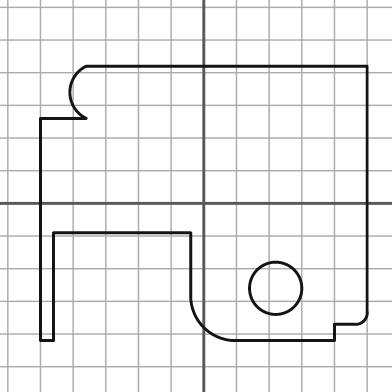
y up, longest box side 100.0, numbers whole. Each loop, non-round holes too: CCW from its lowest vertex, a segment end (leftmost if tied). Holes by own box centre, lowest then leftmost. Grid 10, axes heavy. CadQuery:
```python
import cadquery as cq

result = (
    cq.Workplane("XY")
    .moveTo(-50.0, -42.0)
    .lineTo(-46.0, -42.0)
    .lineTo(-46.0, -9.0)
    .lineTo(-4.0, -9.0)
    .lineTo(-4.0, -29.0)
    .threePointArc((0.0, -38.0), (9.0, -42.0))
    .lineTo(40.0, -42.0)
    .lineTo(40.0, -37.0)
    .lineTo(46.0, -37.0)
    .threePointArc((49.0, -36.0), (50.0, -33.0))
    .lineTo(50.0, 42.0)
    .lineTo(-36.0, 42.0)
    .threePointArc((-41.0, 34.0), (-36.0, 26.0))
    .lineTo(-50.0, 26.0)
    .close()
    .moveTo(22.0, -26.0)
    .circle(8.0)
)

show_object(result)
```